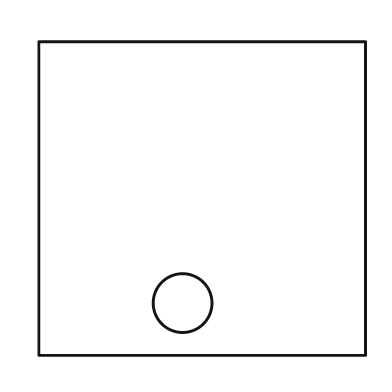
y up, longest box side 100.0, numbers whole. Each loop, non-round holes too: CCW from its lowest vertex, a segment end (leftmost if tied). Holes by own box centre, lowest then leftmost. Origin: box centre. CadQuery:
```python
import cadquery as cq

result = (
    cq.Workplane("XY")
    .moveTo(-50.0, -48.0)
    .lineTo(50.0, -48.0)
    .lineTo(50.0, 48.0)
    .lineTo(-50.0, 48.0)
    .close()
    .moveTo(-6.0, -32.0)
    .circle(9.0)
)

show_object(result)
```